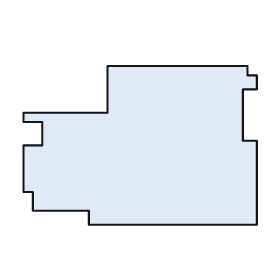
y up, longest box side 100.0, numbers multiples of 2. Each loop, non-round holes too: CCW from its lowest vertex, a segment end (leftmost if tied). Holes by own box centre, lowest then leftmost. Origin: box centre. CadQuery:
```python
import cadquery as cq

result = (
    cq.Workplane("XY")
    .moveTo(-22.0, -34.0)
    .lineTo(50.0, -34.0)
    .lineTo(50.0, 2.0)
    .lineTo(44.0, 2.0)
    .lineTo(44.0, 24.0)
    .lineTo(50.0, 24.0)
    .lineTo(50.0, 30.0)
    .lineTo(46.0, 30.0)
    .lineTo(46.0, 34.0)
    .lineTo(-14.0, 34.0)
    .lineTo(-14.0, 14.0)
    .lineTo(-50.0, 14.0)
    .lineTo(-50.0, 10.0)
    .lineTo(-42.0, 10.0)
    .lineTo(-42.0, 0.0)
    .lineTo(-50.0, 0.0)
    .lineTo(-50.0, -20.0)
    .lineTo(-46.0, -20.0)
    .lineTo(-46.0, -28.0)
    .lineTo(-22.0, -28.0)
    .close()
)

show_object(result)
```